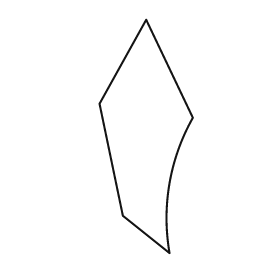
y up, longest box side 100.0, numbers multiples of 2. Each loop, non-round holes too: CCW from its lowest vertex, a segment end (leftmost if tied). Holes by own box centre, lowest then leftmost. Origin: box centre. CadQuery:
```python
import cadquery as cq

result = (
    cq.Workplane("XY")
    .moveTo(10.0, -50.0)
    .threePointArc((10.0, -20.0), (20.0, 8.0))
    .lineTo(0.0, 50.0)
    .lineTo(-20.0, 14.0)
    .lineTo(-10.0, -34.0)
    .close()
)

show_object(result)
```